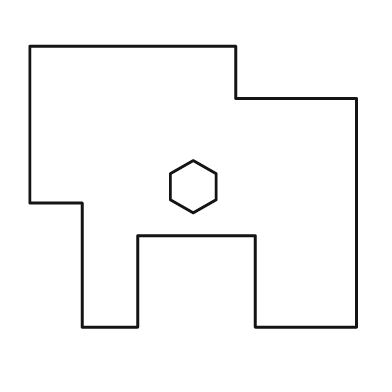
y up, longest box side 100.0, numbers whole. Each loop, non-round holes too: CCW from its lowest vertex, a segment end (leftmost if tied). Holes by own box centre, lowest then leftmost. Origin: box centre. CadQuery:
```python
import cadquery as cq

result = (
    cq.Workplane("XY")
    .moveTo(-34.0, -43.0)
    .lineTo(-17.0, -43.0)
    .lineTo(-17.0, -15.0)
    .lineTo(19.0, -15.0)
    .lineTo(19.0, -43.0)
    .lineTo(50.0, -43.0)
    .lineTo(50.0, 27.0)
    .lineTo(13.0, 27.0)
    .lineTo(13.0, 43.0)
    .lineTo(-50.0, 43.0)
    .lineTo(-50.0, -5.0)
    .lineTo(-34.0, -5.0)
    .close()
    .moveTo(0.0, -8.0)
    .lineTo(7.0, -4.0)
    .lineTo(7.0, 4.0)
    .lineTo(0.0, 8.0)
    .lineTo(-7.0, 4.0)
    .lineTo(-7.0, -4.0)
    .close()
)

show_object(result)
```